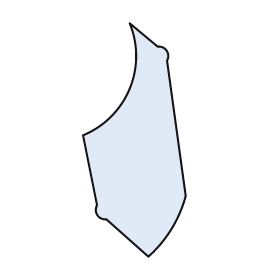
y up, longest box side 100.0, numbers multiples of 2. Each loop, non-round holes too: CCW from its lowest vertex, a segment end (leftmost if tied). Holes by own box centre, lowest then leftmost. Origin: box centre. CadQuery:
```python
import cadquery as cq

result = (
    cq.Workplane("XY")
    .moveTo(6.0, -50.0)
    .threePointArc((16.0, -38.0), (22.0, -24.0))
    .lineTo(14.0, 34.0)
    .threePointArc((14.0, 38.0), (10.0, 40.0))
    .lineTo(-2.0, 50.0)
    .threePointArc((-2.0, 22.0), (-22.0, 2.0))
    .lineTo(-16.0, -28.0)
    .threePointArc((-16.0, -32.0), (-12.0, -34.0))
    .close()
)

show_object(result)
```